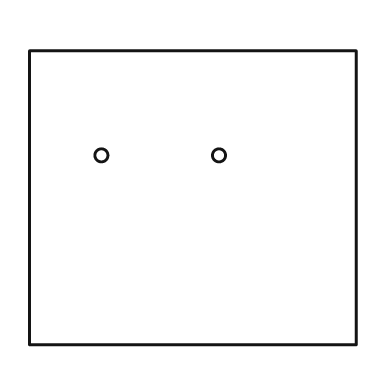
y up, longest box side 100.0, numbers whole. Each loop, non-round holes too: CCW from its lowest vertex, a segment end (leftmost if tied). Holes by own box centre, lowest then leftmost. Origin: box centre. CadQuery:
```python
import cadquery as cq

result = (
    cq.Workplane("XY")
    .moveTo(-50.0, -45.0)
    .lineTo(50.0, -45.0)
    .lineTo(50.0, 45.0)
    .lineTo(-50.0, 45.0)
    .close()
    .moveTo(-28.0, 13.0)
    .circle(2.0)
    .moveTo(8.0, 13.0)
    .circle(2.0)
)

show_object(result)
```